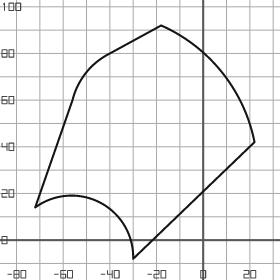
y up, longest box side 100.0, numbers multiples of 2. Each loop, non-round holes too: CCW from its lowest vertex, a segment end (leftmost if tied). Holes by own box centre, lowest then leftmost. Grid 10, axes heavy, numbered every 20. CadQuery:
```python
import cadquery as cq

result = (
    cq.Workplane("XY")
    .moveTo(-30.0, -8.0)
    .lineTo(22.0, 42.0)
    .threePointArc((8.0, 72.0), (-18.0, 92.0))
    .lineTo(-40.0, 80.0)
    .threePointArc((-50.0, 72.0), (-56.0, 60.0))
    .lineTo(-72.0, 14.0)
    .threePointArc((-44.0, 16.0), (-30.0, -8.0))
    .close()
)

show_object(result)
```